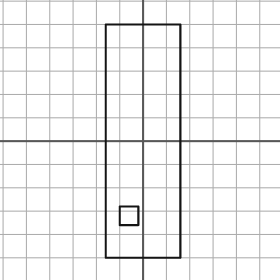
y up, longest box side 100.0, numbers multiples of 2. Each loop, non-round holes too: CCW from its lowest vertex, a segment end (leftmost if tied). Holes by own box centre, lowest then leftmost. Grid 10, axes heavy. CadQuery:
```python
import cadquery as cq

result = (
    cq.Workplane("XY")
    .moveTo(-16.0, -50.0)
    .lineTo(16.0, -50.0)
    .lineTo(16.0, 50.0)
    .lineTo(-16.0, 50.0)
    .close()
    .moveTo(-10.0, -36.0)
    .lineTo(-2.0, -36.0)
    .lineTo(-2.0, -28.0)
    .lineTo(-10.0, -28.0)
    .close()
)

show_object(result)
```